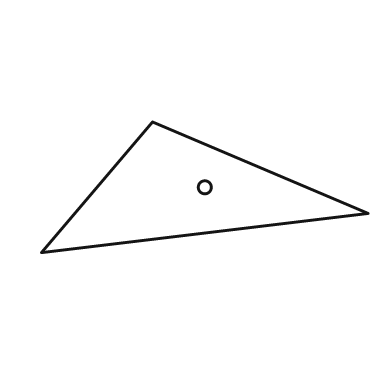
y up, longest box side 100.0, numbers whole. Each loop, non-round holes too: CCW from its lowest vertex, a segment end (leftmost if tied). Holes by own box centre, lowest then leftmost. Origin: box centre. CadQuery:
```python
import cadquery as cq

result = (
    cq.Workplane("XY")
    .moveTo(-50.0, -20.0)
    .lineTo(50.0, -8.0)
    .lineTo(-16.0, 20.0)
    .close()
    .moveTo(0.0, 0.0)
    .circle(2.0)
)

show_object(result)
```